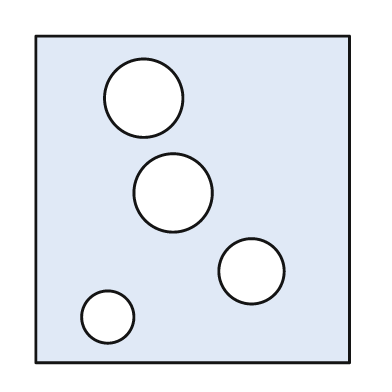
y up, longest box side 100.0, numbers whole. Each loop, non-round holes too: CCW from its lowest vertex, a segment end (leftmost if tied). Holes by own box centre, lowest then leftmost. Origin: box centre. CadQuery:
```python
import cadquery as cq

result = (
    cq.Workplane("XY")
    .moveTo(-48.0, -50.0)
    .lineTo(48.0, -50.0)
    .lineTo(48.0, 50.0)
    .lineTo(-48.0, 50.0)
    .close()
    .moveTo(-26.0, -36.0)
    .circle(8.0)
    .moveTo(18.0, -22.0)
    .circle(10.0)
    .moveTo(-6.0, 2.0)
    .circle(12.0)
    .moveTo(-15.0, 31.0)
    .circle(12.0)
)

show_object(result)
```